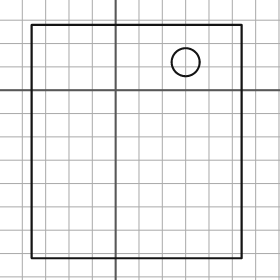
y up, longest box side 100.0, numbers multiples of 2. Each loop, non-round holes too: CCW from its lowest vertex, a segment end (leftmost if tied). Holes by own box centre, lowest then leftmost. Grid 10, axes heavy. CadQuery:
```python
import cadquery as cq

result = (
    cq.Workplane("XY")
    .moveTo(-36.0, -72.0)
    .lineTo(54.0, -72.0)
    .lineTo(54.0, 28.0)
    .lineTo(-36.0, 28.0)
    .close()
    .moveTo(30.0, 12.0)
    .circle(6.0)
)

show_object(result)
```